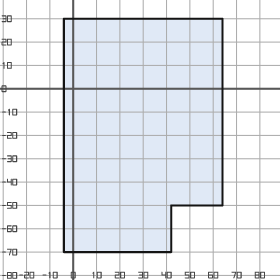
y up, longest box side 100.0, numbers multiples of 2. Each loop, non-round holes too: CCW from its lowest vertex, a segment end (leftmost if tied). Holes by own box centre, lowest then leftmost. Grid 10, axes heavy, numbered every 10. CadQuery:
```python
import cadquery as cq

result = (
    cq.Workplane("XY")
    .moveTo(-4.0, -70.0)
    .lineTo(42.0, -70.0)
    .lineTo(42.0, -50.0)
    .lineTo(64.0, -50.0)
    .lineTo(64.0, 30.0)
    .lineTo(-4.0, 30.0)
    .close()
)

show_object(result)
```